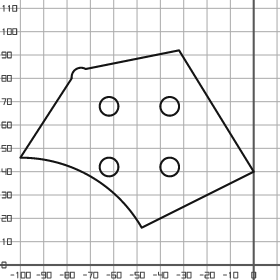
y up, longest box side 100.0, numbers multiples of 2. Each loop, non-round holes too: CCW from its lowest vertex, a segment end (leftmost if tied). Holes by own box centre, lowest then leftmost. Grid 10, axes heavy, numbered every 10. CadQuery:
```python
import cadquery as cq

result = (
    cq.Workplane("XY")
    .moveTo(-48.0, 16.0)
    .lineTo(0.0, 40.0)
    .lineTo(-32.0, 92.0)
    .lineTo(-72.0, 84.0)
    .threePointArc((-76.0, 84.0), (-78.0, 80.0))
    .lineTo(-100.0, 46.0)
    .threePointArc((-70.0, 38.0), (-48.0, 16.0))
    .close()
    .moveTo(-62.0, 42.0)
    .circle(4.0)
    .moveTo(-36.0, 42.0)
    .circle(4.0)
    .moveTo(-62.0, 68.0)
    .circle(4.0)
    .moveTo(-36.0, 68.0)
    .circle(4.0)
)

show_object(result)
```